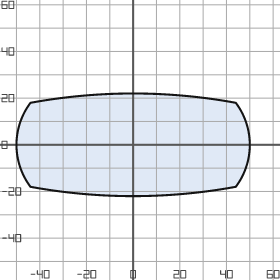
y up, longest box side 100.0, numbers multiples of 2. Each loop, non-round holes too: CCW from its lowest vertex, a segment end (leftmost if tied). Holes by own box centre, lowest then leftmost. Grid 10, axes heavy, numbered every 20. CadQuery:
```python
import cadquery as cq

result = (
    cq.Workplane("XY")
    .moveTo(-44.0, -18.0)
    .threePointArc((0.0, -22.0), (44.0, -18.0))
    .threePointArc((50.0, 0.0), (44.0, 18.0))
    .threePointArc((0.0, 22.0), (-44.0, 18.0))
    .threePointArc((-50.0, 0.0), (-44.0, -18.0))
    .close()
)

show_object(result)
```